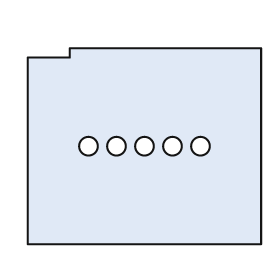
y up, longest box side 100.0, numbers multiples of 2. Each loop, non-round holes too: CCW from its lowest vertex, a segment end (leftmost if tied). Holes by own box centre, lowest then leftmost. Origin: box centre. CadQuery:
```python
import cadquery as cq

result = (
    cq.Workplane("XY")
    .moveTo(-50.0, -42.0)
    .lineTo(50.0, -42.0)
    .lineTo(50.0, 42.0)
    .lineTo(-32.0, 42.0)
    .lineTo(-32.0, 38.0)
    .lineTo(-50.0, 38.0)
    .close()
    .moveTo(-24.0, 0.0)
    .circle(4.0)
    .moveTo(-12.0, 0.0)
    .circle(4.0)
    .moveTo(0.0, 0.0)
    .circle(4.0)
    .moveTo(12.0, 0.0)
    .circle(4.0)
    .moveTo(24.0, 0.0)
    .circle(4.0)
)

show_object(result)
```